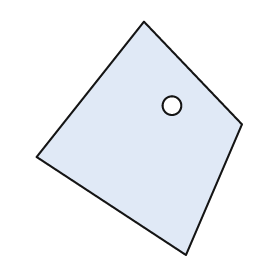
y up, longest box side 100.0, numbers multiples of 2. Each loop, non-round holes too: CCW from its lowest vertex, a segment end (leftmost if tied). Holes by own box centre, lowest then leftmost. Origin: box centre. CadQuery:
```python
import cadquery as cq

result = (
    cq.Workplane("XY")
    .moveTo(20.0, -50.0)
    .lineTo(44.0, 6.0)
    .lineTo(2.0, 50.0)
    .lineTo(-44.0, -8.0)
    .close()
    .moveTo(14.0, 14.0)
    .circle(4.0)
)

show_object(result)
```